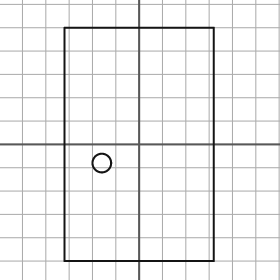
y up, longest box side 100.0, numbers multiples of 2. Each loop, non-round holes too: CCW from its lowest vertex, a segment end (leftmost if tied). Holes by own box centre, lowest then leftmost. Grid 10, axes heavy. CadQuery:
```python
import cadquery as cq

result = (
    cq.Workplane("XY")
    .moveTo(-32.0, -50.0)
    .lineTo(32.0, -50.0)
    .lineTo(32.0, 50.0)
    .lineTo(-32.0, 50.0)
    .close()
    .moveTo(-16.0, -8.0)
    .circle(4.0)
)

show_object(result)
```